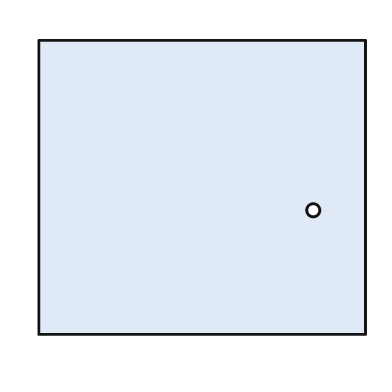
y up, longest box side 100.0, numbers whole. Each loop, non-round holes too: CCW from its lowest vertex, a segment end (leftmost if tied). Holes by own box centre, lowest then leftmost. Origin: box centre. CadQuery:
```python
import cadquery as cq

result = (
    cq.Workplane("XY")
    .moveTo(-50.0, -45.0)
    .lineTo(50.0, -45.0)
    .lineTo(50.0, 45.0)
    .lineTo(-50.0, 45.0)
    .close()
    .moveTo(34.0, -7.0)
    .circle(2.0)
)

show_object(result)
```